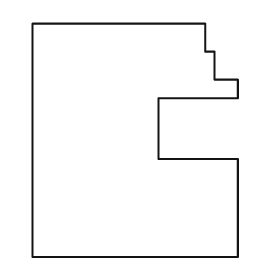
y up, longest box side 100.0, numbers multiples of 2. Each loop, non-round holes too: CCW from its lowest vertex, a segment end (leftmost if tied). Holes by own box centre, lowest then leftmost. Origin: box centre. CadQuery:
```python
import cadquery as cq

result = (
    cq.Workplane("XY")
    .moveTo(-44.0, -50.0)
    .lineTo(44.0, -50.0)
    .lineTo(44.0, -8.0)
    .lineTo(10.0, -8.0)
    .lineTo(10.0, 18.0)
    .lineTo(44.0, 18.0)
    .lineTo(44.0, 26.0)
    .lineTo(34.0, 26.0)
    .lineTo(34.0, 38.0)
    .lineTo(30.0, 38.0)
    .lineTo(30.0, 50.0)
    .lineTo(-44.0, 50.0)
    .close()
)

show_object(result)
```